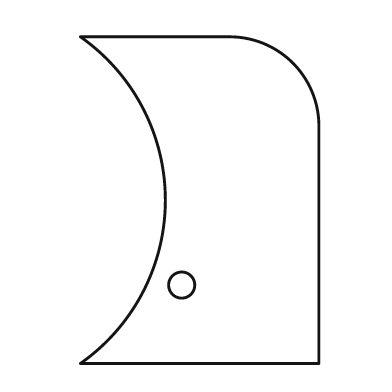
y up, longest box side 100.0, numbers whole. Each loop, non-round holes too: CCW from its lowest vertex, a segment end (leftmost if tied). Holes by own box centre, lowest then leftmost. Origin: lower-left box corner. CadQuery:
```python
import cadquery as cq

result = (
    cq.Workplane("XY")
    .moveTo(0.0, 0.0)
    .lineTo(73.0, 0.0)
    .lineTo(73.0, 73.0)
    .threePointArc((65.0, 92.0), (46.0, 100.0))
    .lineTo(0.0, 100.0)
    .threePointArc((26.0, 50.0), (0.0, 0.0))
    .close()
    .moveTo(31.0, 24.0)
    .circle(4.0)
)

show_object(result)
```